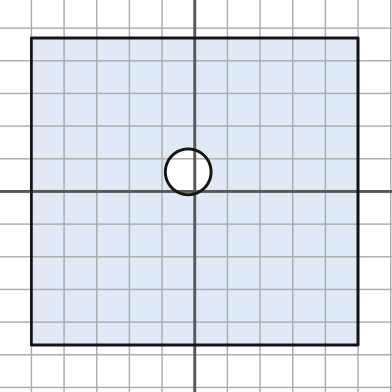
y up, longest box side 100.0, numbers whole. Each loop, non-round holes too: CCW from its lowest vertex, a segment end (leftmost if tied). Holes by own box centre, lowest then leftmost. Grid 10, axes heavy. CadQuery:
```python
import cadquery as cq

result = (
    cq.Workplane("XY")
    .moveTo(-50.0, -47.0)
    .lineTo(50.0, -47.0)
    .lineTo(50.0, 47.0)
    .lineTo(-50.0, 47.0)
    .close()
    .moveTo(-2.0, 6.0)
    .circle(7.0)
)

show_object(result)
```